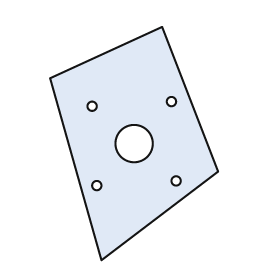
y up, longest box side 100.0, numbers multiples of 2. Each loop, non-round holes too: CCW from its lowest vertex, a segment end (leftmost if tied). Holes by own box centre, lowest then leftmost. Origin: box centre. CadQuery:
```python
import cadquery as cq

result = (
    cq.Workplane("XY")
    .moveTo(-14.0, -50.0)
    .lineTo(36.0, -12.0)
    .lineTo(12.0, 50.0)
    .lineTo(-36.0, 28.0)
    .close()
    .moveTo(-16.0, -18.0)
    .circle(2.0)
    .moveTo(18.0, -16.0)
    .circle(2.0)
    .moveTo(0.0, 0.0)
    .circle(8.0)
    .moveTo(-18.0, 16.0)
    .circle(2.0)
    .moveTo(16.0, 18.0)
    .circle(2.0)
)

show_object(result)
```